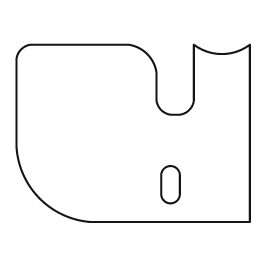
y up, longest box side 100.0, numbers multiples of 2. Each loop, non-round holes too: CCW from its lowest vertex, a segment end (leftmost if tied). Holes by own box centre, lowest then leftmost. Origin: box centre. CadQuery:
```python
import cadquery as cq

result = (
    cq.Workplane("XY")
    .moveTo(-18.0, -38.0)
    .lineTo(50.0, -38.0)
    .lineTo(50.0, 38.0)
    .threePointArc((38.0, 34.0), (26.0, 38.0))
    .lineTo(26.0, 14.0)
    .threePointArc((24.0, 10.0), (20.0, 8.0))
    .lineTo(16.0, 8.0)
    .threePointArc((12.0, 10.0), (10.0, 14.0))
    .lineTo(10.0, 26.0)
    .threePointArc((6.0, 34.0), (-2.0, 38.0))
    .lineTo(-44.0, 38.0)
    .threePointArc((-48.0, 36.0), (-50.0, 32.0))
    .lineTo(-50.0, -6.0)
    .threePointArc((-40.0, -28.0), (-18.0, -38.0))
    .close()
    .moveTo(12.0, -26.0)
    .threePointArc((16.0, -30.0), (20.0, -26.0))
    .lineTo(20.0, -18.0)
    .threePointArc((16.0, -14.0), (12.0, -18.0))
    .close()
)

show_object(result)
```